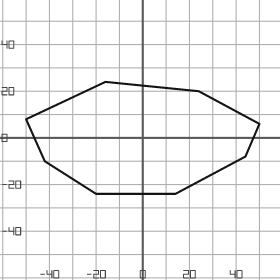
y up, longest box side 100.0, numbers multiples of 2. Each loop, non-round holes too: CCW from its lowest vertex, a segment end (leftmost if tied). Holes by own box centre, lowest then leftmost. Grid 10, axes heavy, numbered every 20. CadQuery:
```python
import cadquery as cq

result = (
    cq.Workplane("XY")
    .moveTo(-20.0, -24.0)
    .lineTo(14.0, -24.0)
    .lineTo(44.0, -8.0)
    .lineTo(50.0, 6.0)
    .lineTo(24.0, 20.0)
    .lineTo(-16.0, 24.0)
    .lineTo(-50.0, 8.0)
    .lineTo(-42.0, -10.0)
    .close()
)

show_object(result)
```